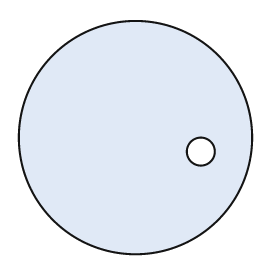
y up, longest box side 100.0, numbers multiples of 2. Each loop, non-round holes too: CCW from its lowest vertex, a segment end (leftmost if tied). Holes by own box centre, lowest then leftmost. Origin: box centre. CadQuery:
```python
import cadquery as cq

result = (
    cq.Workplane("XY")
    .moveTo(0.0, 0.0)
    .circle(50.0)
    .moveTo(28.0, -6.0)
    .circle(6.0)
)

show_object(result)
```